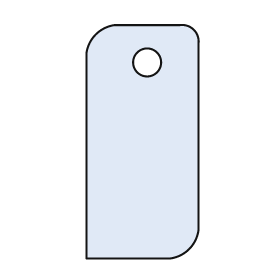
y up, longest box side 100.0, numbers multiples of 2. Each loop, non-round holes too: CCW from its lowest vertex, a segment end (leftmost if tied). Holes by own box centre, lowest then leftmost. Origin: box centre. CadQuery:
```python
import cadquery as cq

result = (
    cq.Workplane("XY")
    .moveTo(-24.0, -50.0)
    .lineTo(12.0, -50.0)
    .threePointArc((20.0, -46.0), (24.0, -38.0))
    .lineTo(24.0, 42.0)
    .threePointArc((22.0, 48.0), (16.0, 50.0))
    .lineTo(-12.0, 50.0)
    .threePointArc((-20.0, 46.0), (-24.0, 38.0))
    .close()
    .moveTo(2.0, 34.0)
    .circle(6.0)
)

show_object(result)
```